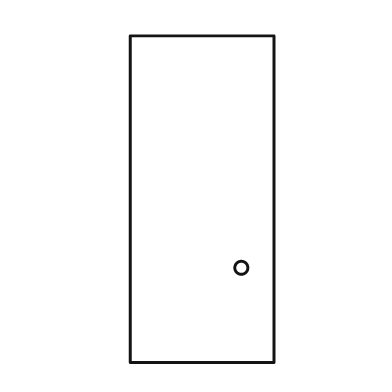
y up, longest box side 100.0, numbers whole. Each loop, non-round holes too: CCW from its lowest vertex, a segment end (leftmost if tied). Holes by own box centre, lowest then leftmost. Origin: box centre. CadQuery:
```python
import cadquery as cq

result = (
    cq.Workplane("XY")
    .moveTo(-22.0, -50.0)
    .lineTo(22.0, -50.0)
    .lineTo(22.0, 50.0)
    .lineTo(-22.0, 50.0)
    .close()
    .moveTo(12.0, -21.0)
    .circle(2.0)
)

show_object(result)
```